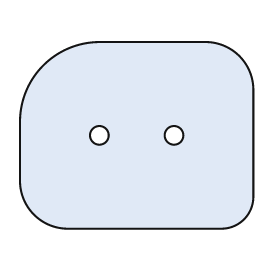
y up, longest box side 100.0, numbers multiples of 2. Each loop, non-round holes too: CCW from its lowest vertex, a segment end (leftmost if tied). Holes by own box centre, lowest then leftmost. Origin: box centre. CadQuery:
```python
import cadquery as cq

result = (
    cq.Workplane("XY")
    .moveTo(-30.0, -40.0)
    .lineTo(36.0, -40.0)
    .threePointArc((46.0, -36.0), (50.0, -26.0))
    .lineTo(50.0, 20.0)
    .threePointArc((44.0, 34.0), (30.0, 40.0))
    .lineTo(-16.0, 40.0)
    .threePointArc((-40.0, 30.0), (-50.0, 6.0))
    .lineTo(-50.0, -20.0)
    .threePointArc((-44.0, -34.0), (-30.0, -40.0))
    .close()
    .moveTo(-16.0, 0.0)
    .circle(4.0)
    .moveTo(16.0, 0.0)
    .circle(4.0)
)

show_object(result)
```